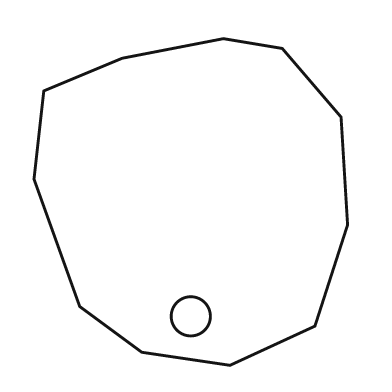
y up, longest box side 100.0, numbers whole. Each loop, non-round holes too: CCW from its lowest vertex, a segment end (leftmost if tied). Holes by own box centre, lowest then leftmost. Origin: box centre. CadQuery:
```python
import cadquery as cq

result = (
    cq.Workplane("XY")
    .moveTo(12.0, -50.0)
    .lineTo(38.0, -38.0)
    .lineTo(48.0, -7.0)
    .lineTo(46.0, 26.0)
    .lineTo(28.0, 47.0)
    .lineTo(10.0, 50.0)
    .lineTo(-21.0, 44.0)
    .lineTo(-45.0, 34.0)
    .lineTo(-48.0, 7.0)
    .lineTo(-34.0, -32.0)
    .lineTo(-15.0, -46.0)
    .close()
    .moveTo(0.0, -35.0)
    .circle(6.0)
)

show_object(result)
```